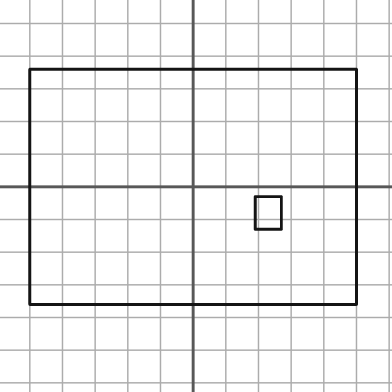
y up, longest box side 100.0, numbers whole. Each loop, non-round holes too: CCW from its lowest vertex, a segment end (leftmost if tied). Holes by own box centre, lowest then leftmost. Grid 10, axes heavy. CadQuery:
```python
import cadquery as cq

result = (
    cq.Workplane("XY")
    .moveTo(-50.0, -36.0)
    .lineTo(50.0, -36.0)
    .lineTo(50.0, 36.0)
    .lineTo(-50.0, 36.0)
    .close()
    .moveTo(19.0, -13.0)
    .lineTo(27.0, -13.0)
    .lineTo(27.0, -3.0)
    .lineTo(19.0, -3.0)
    .close()
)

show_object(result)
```